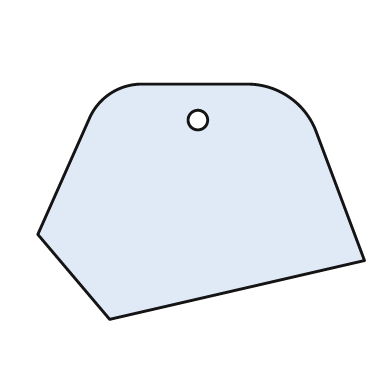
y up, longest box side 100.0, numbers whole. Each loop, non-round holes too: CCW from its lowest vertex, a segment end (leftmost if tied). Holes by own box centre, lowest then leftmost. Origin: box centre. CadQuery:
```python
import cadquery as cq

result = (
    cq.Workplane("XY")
    .moveTo(-28.0, -36.0)
    .lineTo(50.0, -18.0)
    .lineTo(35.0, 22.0)
    .threePointArc((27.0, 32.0), (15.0, 36.0))
    .lineTo(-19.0, 36.0)
    .threePointArc((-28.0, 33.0), (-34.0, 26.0))
    .lineTo(-50.0, -10.0)
    .close()
    .moveTo(-1.0, 25.0)
    .circle(3.0)
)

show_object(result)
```